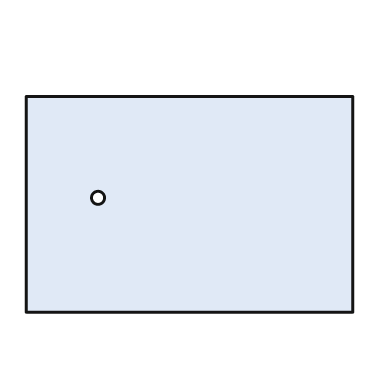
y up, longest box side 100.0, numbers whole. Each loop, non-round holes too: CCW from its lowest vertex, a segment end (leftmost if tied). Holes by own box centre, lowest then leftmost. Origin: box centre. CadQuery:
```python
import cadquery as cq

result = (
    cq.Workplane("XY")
    .moveTo(-50.0, -33.0)
    .lineTo(50.0, -33.0)
    .lineTo(50.0, 33.0)
    .lineTo(-50.0, 33.0)
    .close()
    .moveTo(-28.0, 2.0)
    .circle(2.0)
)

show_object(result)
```